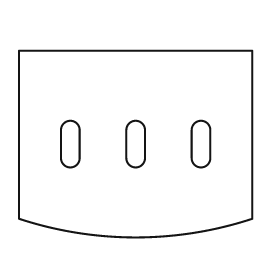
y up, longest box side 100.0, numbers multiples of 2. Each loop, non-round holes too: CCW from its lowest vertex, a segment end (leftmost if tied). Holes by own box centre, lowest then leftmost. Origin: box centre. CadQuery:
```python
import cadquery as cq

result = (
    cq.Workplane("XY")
    .moveTo(-50.0, -32.0)
    .threePointArc((0.0, -40.0), (50.0, -32.0))
    .lineTo(50.0, 40.0)
    .lineTo(-50.0, 40.0)
    .close()
    .moveTo(-32.0, -6.0)
    .threePointArc((-28.0, -10.0), (-24.0, -6.0))
    .lineTo(-24.0, 6.0)
    .threePointArc((-28.0, 10.0), (-32.0, 6.0))
    .close()
    .moveTo(-4.0, -6.0)
    .threePointArc((0.0, -10.0), (4.0, -6.0))
    .lineTo(4.0, 6.0)
    .threePointArc((0.0, 10.0), (-4.0, 6.0))
    .close()
    .moveTo(24.0, -6.0)
    .threePointArc((28.0, -10.0), (32.0, -6.0))
    .lineTo(32.0, 6.0)
    .threePointArc((28.0, 10.0), (24.0, 6.0))
    .close()
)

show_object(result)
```